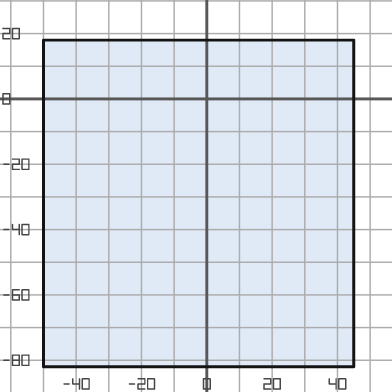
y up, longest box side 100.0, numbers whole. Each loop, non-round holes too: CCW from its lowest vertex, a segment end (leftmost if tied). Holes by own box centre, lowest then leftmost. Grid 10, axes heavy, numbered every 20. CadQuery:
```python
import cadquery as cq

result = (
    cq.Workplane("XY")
    .moveTo(-50.0, -82.0)
    .lineTo(45.0, -82.0)
    .lineTo(45.0, 18.0)
    .lineTo(-50.0, 18.0)
    .close()
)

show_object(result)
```